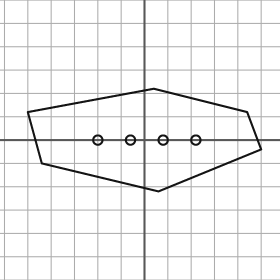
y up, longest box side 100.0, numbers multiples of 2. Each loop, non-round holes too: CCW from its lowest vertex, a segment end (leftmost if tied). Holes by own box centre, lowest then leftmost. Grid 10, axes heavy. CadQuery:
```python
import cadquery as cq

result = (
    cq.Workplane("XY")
    .moveTo(6.0, -22.0)
    .lineTo(50.0, -4.0)
    .lineTo(44.0, 12.0)
    .lineTo(4.0, 22.0)
    .lineTo(-50.0, 12.0)
    .lineTo(-44.0, -10.0)
    .close()
    .moveTo(-20.0, 0.0)
    .circle(2.0)
    .moveTo(-6.0, 0.0)
    .circle(2.0)
    .moveTo(8.0, 0.0)
    .circle(2.0)
    .moveTo(22.0, 0.0)
    .circle(2.0)
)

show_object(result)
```